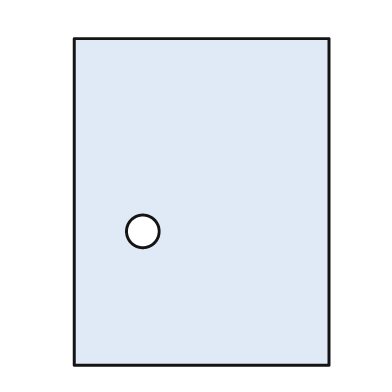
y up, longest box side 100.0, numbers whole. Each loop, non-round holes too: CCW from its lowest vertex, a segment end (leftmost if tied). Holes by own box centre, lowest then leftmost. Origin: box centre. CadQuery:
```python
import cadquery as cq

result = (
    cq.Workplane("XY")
    .moveTo(-39.0, -50.0)
    .lineTo(39.0, -50.0)
    .lineTo(39.0, 50.0)
    .lineTo(-39.0, 50.0)
    .close()
    .moveTo(-18.0, -9.0)
    .circle(5.0)
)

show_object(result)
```